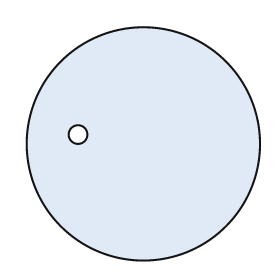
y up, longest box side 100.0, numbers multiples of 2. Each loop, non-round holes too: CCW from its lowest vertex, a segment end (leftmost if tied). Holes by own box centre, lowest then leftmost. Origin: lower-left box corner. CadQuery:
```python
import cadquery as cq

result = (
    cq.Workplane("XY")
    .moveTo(50.0, 50.0)
    .circle(50.0)
    .moveTo(22.0, 54.0)
    .circle(4.0)
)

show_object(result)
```